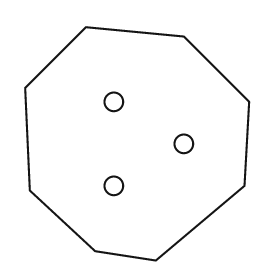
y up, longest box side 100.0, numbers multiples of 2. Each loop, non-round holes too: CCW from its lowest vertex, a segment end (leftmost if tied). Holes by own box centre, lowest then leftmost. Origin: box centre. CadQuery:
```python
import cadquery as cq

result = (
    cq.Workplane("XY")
    .moveTo(8.0, -50.0)
    .lineTo(46.0, -18.0)
    .lineTo(48.0, 18.0)
    .lineTo(20.0, 46.0)
    .lineTo(-22.0, 50.0)
    .lineTo(-48.0, 24.0)
    .lineTo(-46.0, -20.0)
    .lineTo(-18.0, -46.0)
    .close()
    .moveTo(-10.0, -18.0)
    .circle(4.0)
    .moveTo(20.0, 0.0)
    .circle(4.0)
    .moveTo(-10.0, 18.0)
    .circle(4.0)
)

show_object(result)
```